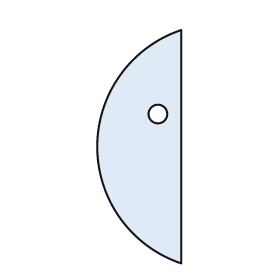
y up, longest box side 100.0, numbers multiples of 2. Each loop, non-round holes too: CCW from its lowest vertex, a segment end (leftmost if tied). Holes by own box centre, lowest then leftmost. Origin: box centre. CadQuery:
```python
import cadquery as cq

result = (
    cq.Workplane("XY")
    .moveTo(18.0, -50.0)
    .lineTo(18.0, 50.0)
    .threePointArc((-18.0, 0.0), (18.0, -50.0))
    .close()
    .moveTo(8.0, 14.0)
    .circle(4.0)
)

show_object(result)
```